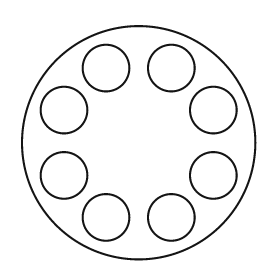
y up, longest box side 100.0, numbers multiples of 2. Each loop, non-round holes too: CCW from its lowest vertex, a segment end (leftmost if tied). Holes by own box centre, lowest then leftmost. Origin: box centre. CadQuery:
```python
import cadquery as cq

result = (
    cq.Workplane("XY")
    .moveTo(0.0, 0.0)
    .circle(50.0)
    .moveTo(-14.0, -32.0)
    .circle(10.0)
    .moveTo(14.0, -32.0)
    .circle(10.0)
    .moveTo(-32.0, -14.0)
    .circle(10.0)
    .moveTo(32.0, -14.0)
    .circle(10.0)
    .moveTo(-32.0, 14.0)
    .circle(10.0)
    .moveTo(32.0, 14.0)
    .circle(10.0)
    .moveTo(-14.0, 32.0)
    .circle(10.0)
    .moveTo(14.0, 32.0)
    .circle(10.0)
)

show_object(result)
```